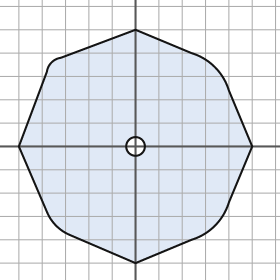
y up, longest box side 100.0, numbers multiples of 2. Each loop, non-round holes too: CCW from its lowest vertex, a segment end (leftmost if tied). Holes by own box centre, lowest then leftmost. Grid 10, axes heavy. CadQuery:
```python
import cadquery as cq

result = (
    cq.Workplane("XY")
    .moveTo(0.0, -50.0)
    .lineTo(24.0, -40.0)
    .threePointArc((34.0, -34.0), (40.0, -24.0))
    .lineTo(50.0, 0.0)
    .lineTo(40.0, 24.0)
    .threePointArc((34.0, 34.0), (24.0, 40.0))
    .lineTo(0.0, 50.0)
    .lineTo(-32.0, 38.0)
    .threePointArc((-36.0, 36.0), (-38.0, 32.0))
    .lineTo(-50.0, 0.0)
    .lineTo(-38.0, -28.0)
    .threePointArc((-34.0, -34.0), (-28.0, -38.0))
    .close()
    .moveTo(0.0, 0.0)
    .circle(4.0)
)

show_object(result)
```